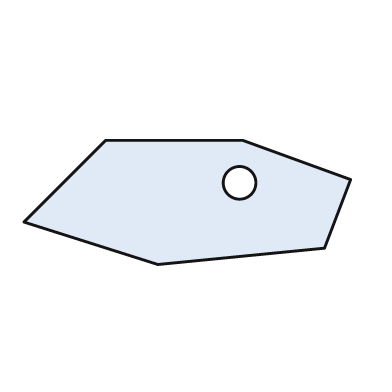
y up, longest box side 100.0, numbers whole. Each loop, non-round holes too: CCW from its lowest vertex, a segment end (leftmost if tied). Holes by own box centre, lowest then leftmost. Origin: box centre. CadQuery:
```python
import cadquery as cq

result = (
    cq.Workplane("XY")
    .moveTo(-9.0, -19.0)
    .lineTo(42.0, -14.0)
    .lineTo(50.0, 7.0)
    .lineTo(17.0, 19.0)
    .lineTo(-25.0, 19.0)
    .lineTo(-50.0, -6.0)
    .close()
    .moveTo(16.0, 6.0)
    .circle(5.0)
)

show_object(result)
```